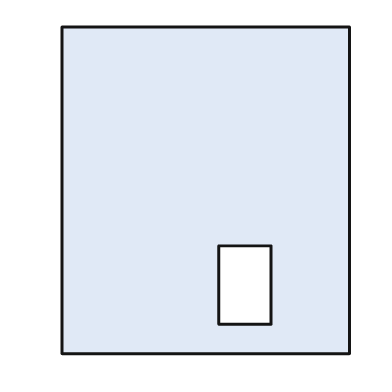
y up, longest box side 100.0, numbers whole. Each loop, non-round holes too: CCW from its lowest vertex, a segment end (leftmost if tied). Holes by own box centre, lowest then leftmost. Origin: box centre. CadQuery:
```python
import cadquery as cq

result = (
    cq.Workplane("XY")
    .moveTo(-44.0, -50.0)
    .lineTo(44.0, -50.0)
    .lineTo(44.0, 50.0)
    .lineTo(-44.0, 50.0)
    .close()
    .moveTo(4.0, -41.0)
    .lineTo(20.0, -41.0)
    .lineTo(20.0, -17.0)
    .lineTo(4.0, -17.0)
    .close()
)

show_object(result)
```